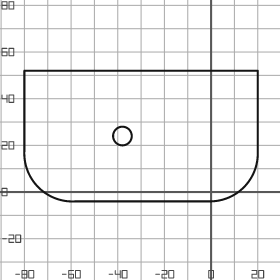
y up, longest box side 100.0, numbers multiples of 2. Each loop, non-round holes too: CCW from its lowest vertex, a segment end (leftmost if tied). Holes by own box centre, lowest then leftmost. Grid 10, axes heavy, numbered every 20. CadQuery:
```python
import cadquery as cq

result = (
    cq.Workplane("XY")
    .moveTo(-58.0, -4.0)
    .lineTo(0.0, -4.0)
    .threePointArc((14.0, 2.0), (20.0, 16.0))
    .lineTo(20.0, 52.0)
    .lineTo(-80.0, 52.0)
    .lineTo(-80.0, 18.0)
    .threePointArc((-74.0, 2.0), (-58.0, -4.0))
    .close()
    .moveTo(-38.0, 24.0)
    .circle(4.0)
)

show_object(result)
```